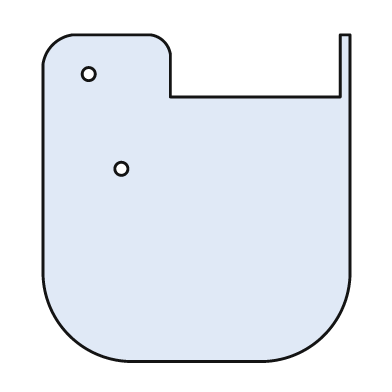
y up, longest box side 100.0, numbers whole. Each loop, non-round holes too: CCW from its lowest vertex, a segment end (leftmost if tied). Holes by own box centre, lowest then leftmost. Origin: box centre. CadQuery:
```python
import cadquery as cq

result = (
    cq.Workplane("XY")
    .moveTo(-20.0, -50.0)
    .lineTo(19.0, -50.0)
    .threePointArc((39.0, -42.0), (47.0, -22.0))
    .lineTo(47.0, 50.0)
    .lineTo(44.0, 50.0)
    .lineTo(44.0, 31.0)
    .lineTo(-8.0, 31.0)
    .lineTo(-8.0, 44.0)
    .threePointArc((-10.0, 48.0), (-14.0, 50.0))
    .lineTo(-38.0, 50.0)
    .threePointArc((-44.0, 47.0), (-47.0, 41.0))
    .lineTo(-47.0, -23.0)
    .threePointArc((-39.0, -42.0), (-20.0, -50.0))
    .close()
    .moveTo(-23.0, 9.0)
    .circle(2.0)
    .moveTo(-33.0, 38.0)
    .circle(2.0)
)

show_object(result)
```